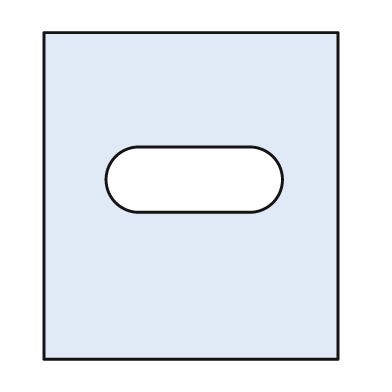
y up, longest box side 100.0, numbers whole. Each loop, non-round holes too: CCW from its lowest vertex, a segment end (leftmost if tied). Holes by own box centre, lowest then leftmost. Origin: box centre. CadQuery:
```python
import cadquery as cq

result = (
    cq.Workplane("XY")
    .moveTo(-45.0, -50.0)
    .lineTo(45.0, -50.0)
    .lineTo(45.0, 50.0)
    .lineTo(-45.0, 50.0)
    .close()
    .moveTo(-16.0, -5.0)
    .lineTo(18.0, -5.0)
    .threePointArc((28.0, 5.0), (18.0, 15.0))
    .lineTo(-16.0, 15.0)
    .threePointArc((-26.0, 5.0), (-16.0, -5.0))
    .close()
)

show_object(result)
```